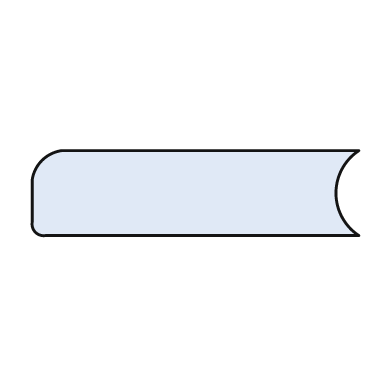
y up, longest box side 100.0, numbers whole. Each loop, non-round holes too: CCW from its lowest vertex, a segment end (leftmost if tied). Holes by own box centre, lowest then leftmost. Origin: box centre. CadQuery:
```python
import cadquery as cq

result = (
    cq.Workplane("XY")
    .moveTo(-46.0, -13.0)
    .lineTo(50.0, -13.0)
    .threePointArc((43.0, 0.0), (50.0, 13.0))
    .lineTo(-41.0, 13.0)
    .threePointArc((-47.0, 10.0), (-50.0, 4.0))
    .lineTo(-50.0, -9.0)
    .threePointArc((-49.0, -12.0), (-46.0, -13.0))
    .close()
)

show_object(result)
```